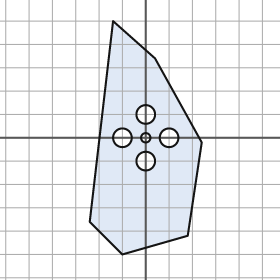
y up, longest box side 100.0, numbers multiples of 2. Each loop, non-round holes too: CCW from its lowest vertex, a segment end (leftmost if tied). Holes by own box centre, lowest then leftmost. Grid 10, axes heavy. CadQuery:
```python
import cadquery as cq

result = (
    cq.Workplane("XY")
    .moveTo(-10.0, -50.0)
    .lineTo(18.0, -42.0)
    .lineTo(24.0, -2.0)
    .lineTo(4.0, 34.0)
    .lineTo(-14.0, 50.0)
    .lineTo(-24.0, -36.0)
    .close()
    .moveTo(0.0, -10.0)
    .circle(4.0)
    .moveTo(-10.0, 0.0)
    .circle(4.0)
    .moveTo(0.0, 0.0)
    .circle(2.0)
    .moveTo(10.0, 0.0)
    .circle(4.0)
    .moveTo(0.0, 10.0)
    .circle(4.0)
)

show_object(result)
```